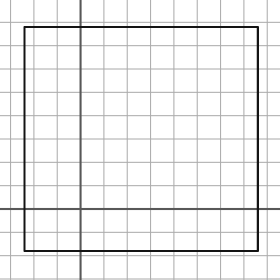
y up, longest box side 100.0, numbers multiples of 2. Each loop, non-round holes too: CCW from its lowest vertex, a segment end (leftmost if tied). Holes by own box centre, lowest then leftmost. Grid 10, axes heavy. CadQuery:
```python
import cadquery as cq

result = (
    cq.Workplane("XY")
    .moveTo(-24.0, -18.0)
    .lineTo(76.0, -18.0)
    .lineTo(76.0, 78.0)
    .lineTo(-24.0, 78.0)
    .close()
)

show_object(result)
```